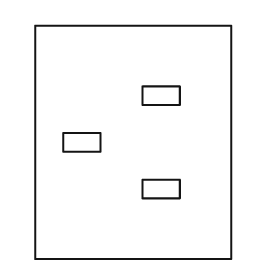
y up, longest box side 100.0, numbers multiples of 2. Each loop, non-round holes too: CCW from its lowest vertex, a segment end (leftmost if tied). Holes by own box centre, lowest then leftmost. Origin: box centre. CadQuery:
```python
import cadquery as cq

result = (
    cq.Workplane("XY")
    .moveTo(-42.0, -50.0)
    .lineTo(42.0, -50.0)
    .lineTo(42.0, 50.0)
    .lineTo(-42.0, 50.0)
    .close()
    .moveTo(4.0, -24.0)
    .lineTo(20.0, -24.0)
    .lineTo(20.0, -16.0)
    .lineTo(4.0, -16.0)
    .close()
    .moveTo(-30.0, -4.0)
    .lineTo(-14.0, -4.0)
    .lineTo(-14.0, 4.0)
    .lineTo(-30.0, 4.0)
    .close()
    .moveTo(4.0, 16.0)
    .lineTo(20.0, 16.0)
    .lineTo(20.0, 24.0)
    .lineTo(4.0, 24.0)
    .close()
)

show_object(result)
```